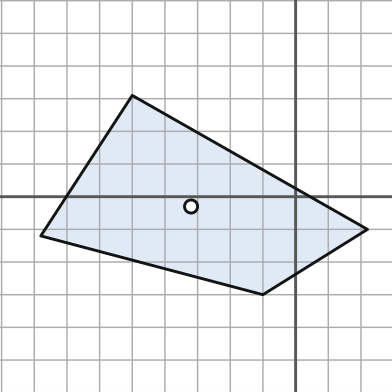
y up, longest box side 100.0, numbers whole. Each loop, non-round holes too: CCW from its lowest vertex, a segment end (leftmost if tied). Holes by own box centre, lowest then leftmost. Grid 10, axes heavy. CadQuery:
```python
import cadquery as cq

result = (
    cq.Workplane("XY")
    .moveTo(-10.0, -30.0)
    .lineTo(22.0, -10.0)
    .lineTo(-50.0, 31.0)
    .lineTo(-78.0, -12.0)
    .close()
    .moveTo(-32.0, -3.0)
    .circle(2.0)
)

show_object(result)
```